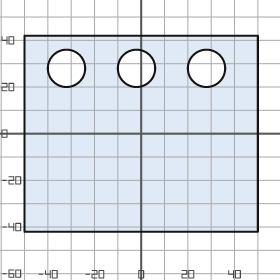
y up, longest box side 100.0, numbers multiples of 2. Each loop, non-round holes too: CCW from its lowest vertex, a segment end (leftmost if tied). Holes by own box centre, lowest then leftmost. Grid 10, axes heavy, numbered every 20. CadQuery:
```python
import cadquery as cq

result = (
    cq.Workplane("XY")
    .moveTo(-50.0, -42.0)
    .lineTo(50.0, -42.0)
    .lineTo(50.0, 42.0)
    .lineTo(-50.0, 42.0)
    .close()
    .moveTo(-32.0, 28.0)
    .circle(8.0)
    .moveTo(-2.0, 28.0)
    .circle(8.0)
    .moveTo(28.0, 28.0)
    .circle(8.0)
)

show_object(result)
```